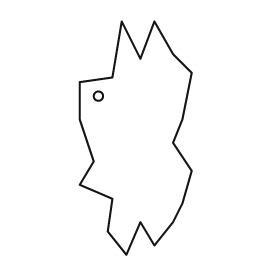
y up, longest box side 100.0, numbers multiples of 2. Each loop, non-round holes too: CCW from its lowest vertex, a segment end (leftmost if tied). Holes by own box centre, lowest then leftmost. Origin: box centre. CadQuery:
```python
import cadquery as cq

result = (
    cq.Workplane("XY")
    .moveTo(-4.0, -50.0)
    .lineTo(2.0, -36.0)
    .lineTo(8.0, -46.0)
    .lineTo(16.0, -36.0)
    .lineTo(20.0, -28.0)
    .lineTo(24.0, -14.0)
    .lineTo(16.0, -2.0)
    .lineTo(20.0, 8.0)
    .lineTo(24.0, 28.0)
    .lineTo(16.0, 36.0)
    .lineTo(8.0, 50.0)
    .lineTo(2.0, 34.0)
    .lineTo(-6.0, 50.0)
    .lineTo(-10.0, 26.0)
    .lineTo(-24.0, 24.0)
    .lineTo(-24.0, 8.0)
    .lineTo(-18.0, -10.0)
    .lineTo(-24.0, -20.0)
    .lineTo(-10.0, -26.0)
    .lineTo(-12.0, -40.0)
    .close()
    .moveTo(-16.0, 18.0)
    .circle(2.0)
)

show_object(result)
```